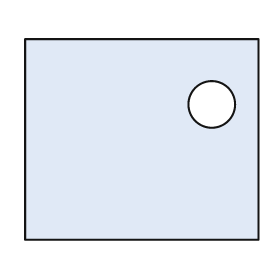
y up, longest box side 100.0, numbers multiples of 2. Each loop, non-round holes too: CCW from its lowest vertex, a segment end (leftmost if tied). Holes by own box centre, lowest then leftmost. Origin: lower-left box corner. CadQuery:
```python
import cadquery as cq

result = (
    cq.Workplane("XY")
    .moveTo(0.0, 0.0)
    .lineTo(100.0, 0.0)
    .lineTo(100.0, 86.0)
    .lineTo(0.0, 86.0)
    .close()
    .moveTo(80.0, 58.0)
    .circle(10.0)
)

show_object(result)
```